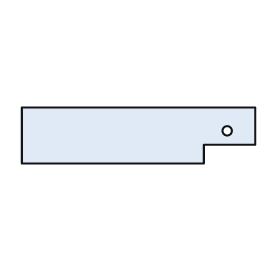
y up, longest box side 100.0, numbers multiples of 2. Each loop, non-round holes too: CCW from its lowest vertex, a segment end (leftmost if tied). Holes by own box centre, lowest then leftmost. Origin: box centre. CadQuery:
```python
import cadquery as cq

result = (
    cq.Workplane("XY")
    .moveTo(-50.0, -12.0)
    .lineTo(28.0, -12.0)
    .lineTo(28.0, -4.0)
    .lineTo(50.0, -4.0)
    .lineTo(50.0, 12.0)
    .lineTo(-50.0, 12.0)
    .close()
    .moveTo(38.0, 2.0)
    .circle(2.0)
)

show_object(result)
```